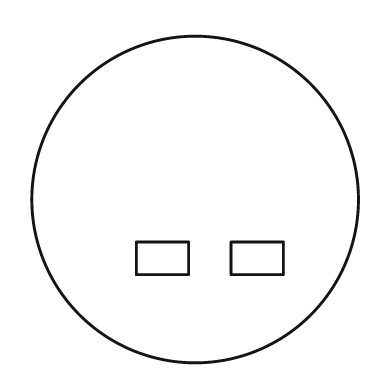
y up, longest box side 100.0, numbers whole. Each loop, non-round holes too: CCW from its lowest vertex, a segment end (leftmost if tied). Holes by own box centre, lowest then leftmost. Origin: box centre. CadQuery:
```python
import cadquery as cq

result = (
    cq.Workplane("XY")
    .moveTo(0.0, 0.0)
    .circle(50.0)
    .moveTo(-18.0, -23.0)
    .lineTo(-2.0, -23.0)
    .lineTo(-2.0, -13.0)
    .lineTo(-18.0, -13.0)
    .close()
    .moveTo(11.0, -23.0)
    .lineTo(27.0, -23.0)
    .lineTo(27.0, -13.0)
    .lineTo(11.0, -13.0)
    .close()
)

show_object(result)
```